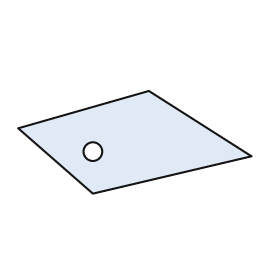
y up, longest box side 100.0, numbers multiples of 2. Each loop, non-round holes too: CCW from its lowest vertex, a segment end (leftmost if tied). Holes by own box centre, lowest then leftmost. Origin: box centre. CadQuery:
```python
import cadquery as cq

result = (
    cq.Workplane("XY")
    .moveTo(-18.0, -22.0)
    .lineTo(50.0, -6.0)
    .lineTo(6.0, 22.0)
    .lineTo(-50.0, 6.0)
    .close()
    .moveTo(-18.0, -4.0)
    .circle(4.0)
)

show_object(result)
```